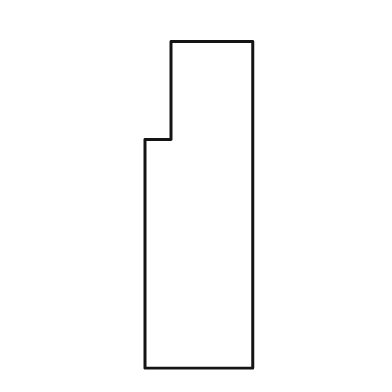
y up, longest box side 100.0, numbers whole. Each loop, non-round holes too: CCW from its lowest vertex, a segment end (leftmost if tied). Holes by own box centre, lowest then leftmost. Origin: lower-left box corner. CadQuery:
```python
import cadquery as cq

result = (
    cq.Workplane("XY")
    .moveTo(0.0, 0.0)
    .lineTo(33.0, 0.0)
    .lineTo(33.0, 100.0)
    .lineTo(8.0, 100.0)
    .lineTo(8.0, 70.0)
    .lineTo(0.0, 70.0)
    .close()
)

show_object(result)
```